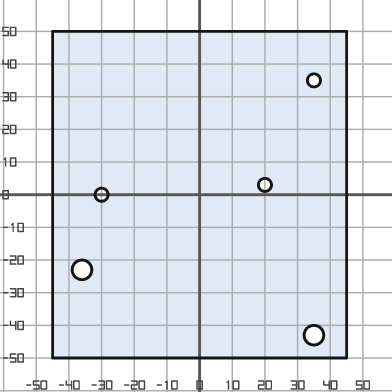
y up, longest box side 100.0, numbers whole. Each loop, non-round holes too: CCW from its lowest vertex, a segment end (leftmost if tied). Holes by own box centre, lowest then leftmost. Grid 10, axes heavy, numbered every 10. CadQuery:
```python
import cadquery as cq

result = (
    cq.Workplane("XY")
    .moveTo(-45.0, -50.0)
    .lineTo(45.0, -50.0)
    .lineTo(45.0, 50.0)
    .lineTo(-45.0, 50.0)
    .close()
    .moveTo(35.0, -43.0)
    .circle(3.0)
    .moveTo(-36.0, -23.0)
    .circle(3.0)
    .moveTo(-30.0, 0.0)
    .circle(2.0)
    .moveTo(20.0, 3.0)
    .circle(2.0)
    .moveTo(35.0, 35.0)
    .circle(2.0)
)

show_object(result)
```